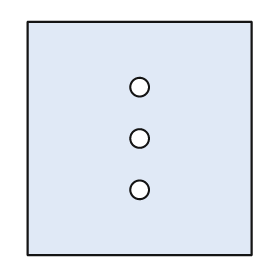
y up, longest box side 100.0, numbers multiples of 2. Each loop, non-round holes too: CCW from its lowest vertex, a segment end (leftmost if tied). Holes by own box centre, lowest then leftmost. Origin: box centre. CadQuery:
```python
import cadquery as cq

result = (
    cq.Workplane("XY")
    .moveTo(-48.0, -50.0)
    .lineTo(48.0, -50.0)
    .lineTo(48.0, 50.0)
    .lineTo(-48.0, 50.0)
    .close()
    .moveTo(0.0, -22.0)
    .circle(4.0)
    .moveTo(0.0, 0.0)
    .circle(4.0)
    .moveTo(0.0, 22.0)
    .circle(4.0)
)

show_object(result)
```